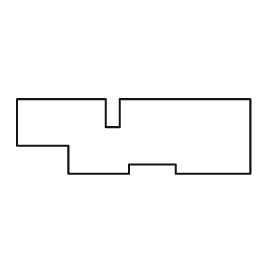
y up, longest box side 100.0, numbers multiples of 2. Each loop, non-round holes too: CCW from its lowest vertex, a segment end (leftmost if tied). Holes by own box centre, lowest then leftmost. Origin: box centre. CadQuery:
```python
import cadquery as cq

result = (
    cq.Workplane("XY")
    .moveTo(-28.0, -16.0)
    .lineTo(-2.0, -16.0)
    .lineTo(-2.0, -12.0)
    .lineTo(18.0, -12.0)
    .lineTo(18.0, -16.0)
    .lineTo(50.0, -16.0)
    .lineTo(50.0, 16.0)
    .lineTo(-6.0, 16.0)
    .lineTo(-6.0, 4.0)
    .lineTo(-12.0, 4.0)
    .lineTo(-12.0, 16.0)
    .lineTo(-50.0, 16.0)
    .lineTo(-50.0, -4.0)
    .lineTo(-28.0, -4.0)
    .close()
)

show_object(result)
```